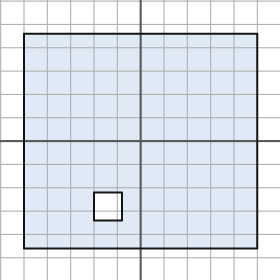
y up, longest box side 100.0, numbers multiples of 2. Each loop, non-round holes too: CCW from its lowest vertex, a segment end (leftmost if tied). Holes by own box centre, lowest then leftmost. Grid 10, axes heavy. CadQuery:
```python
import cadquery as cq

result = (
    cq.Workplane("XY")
    .moveTo(-50.0, -46.0)
    .lineTo(50.0, -46.0)
    .lineTo(50.0, 46.0)
    .lineTo(-50.0, 46.0)
    .close()
    .moveTo(-20.0, -34.0)
    .lineTo(-8.0, -34.0)
    .lineTo(-8.0, -22.0)
    .lineTo(-20.0, -22.0)
    .close()
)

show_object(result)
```